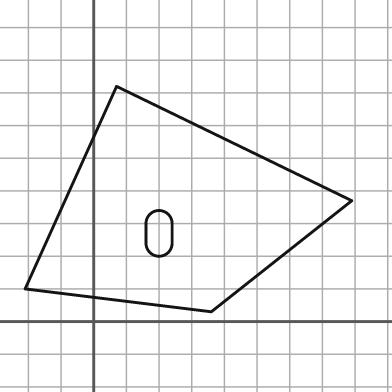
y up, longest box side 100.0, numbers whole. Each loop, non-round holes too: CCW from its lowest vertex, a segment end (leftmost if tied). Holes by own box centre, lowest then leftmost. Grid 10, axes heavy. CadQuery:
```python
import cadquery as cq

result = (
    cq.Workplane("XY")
    .moveTo(36.0, 3.0)
    .lineTo(79.0, 37.0)
    .lineTo(7.0, 72.0)
    .lineTo(-21.0, 10.0)
    .close()
    .moveTo(16.0, 24.0)
    .threePointArc((20.0, 20.0), (24.0, 24.0))
    .lineTo(24.0, 30.0)
    .threePointArc((20.0, 34.0), (16.0, 30.0))
    .close()
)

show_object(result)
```